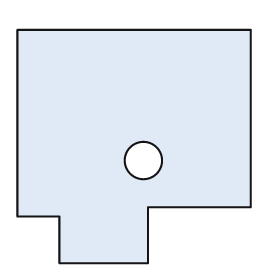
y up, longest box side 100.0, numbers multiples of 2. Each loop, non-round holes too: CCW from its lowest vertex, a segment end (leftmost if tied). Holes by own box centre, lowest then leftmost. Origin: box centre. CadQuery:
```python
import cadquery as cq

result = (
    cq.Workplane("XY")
    .moveTo(-32.0, -50.0)
    .lineTo(6.0, -50.0)
    .lineTo(6.0, -26.0)
    .lineTo(50.0, -26.0)
    .lineTo(50.0, 50.0)
    .lineTo(-50.0, 50.0)
    .lineTo(-50.0, -30.0)
    .lineTo(-32.0, -30.0)
    .close()
    .moveTo(4.0, -6.0)
    .circle(8.0)
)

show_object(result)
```